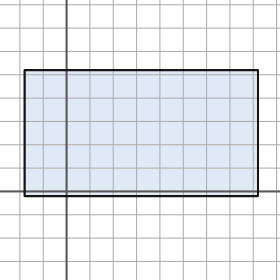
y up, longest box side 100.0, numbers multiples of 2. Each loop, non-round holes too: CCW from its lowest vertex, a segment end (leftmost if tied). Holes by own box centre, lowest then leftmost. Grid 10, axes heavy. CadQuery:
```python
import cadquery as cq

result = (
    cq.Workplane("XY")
    .moveTo(-18.0, -2.0)
    .lineTo(82.0, -2.0)
    .lineTo(82.0, 52.0)
    .lineTo(-18.0, 52.0)
    .close()
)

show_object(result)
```